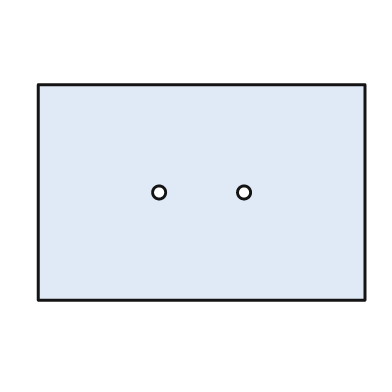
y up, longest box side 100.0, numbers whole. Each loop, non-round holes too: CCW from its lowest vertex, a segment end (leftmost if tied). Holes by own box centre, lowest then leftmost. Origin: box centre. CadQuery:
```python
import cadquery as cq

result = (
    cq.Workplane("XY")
    .moveTo(-50.0, -33.0)
    .lineTo(50.0, -33.0)
    .lineTo(50.0, 33.0)
    .lineTo(-50.0, 33.0)
    .close()
    .moveTo(-13.0, 0.0)
    .circle(2.0)
    .moveTo(13.0, 0.0)
    .circle(2.0)
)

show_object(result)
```